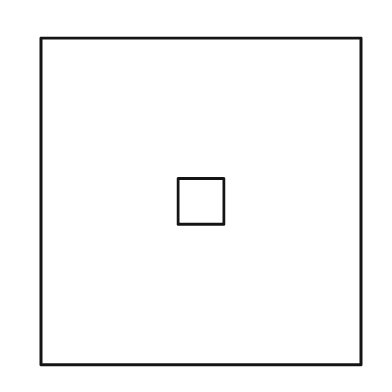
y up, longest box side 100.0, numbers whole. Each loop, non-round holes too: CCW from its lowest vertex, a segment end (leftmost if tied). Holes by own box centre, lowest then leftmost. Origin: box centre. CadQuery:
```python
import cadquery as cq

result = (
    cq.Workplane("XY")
    .moveTo(-49.0, -50.0)
    .lineTo(49.0, -50.0)
    .lineTo(49.0, 50.0)
    .lineTo(-49.0, 50.0)
    .close()
    .moveTo(-7.0, -7.0)
    .lineTo(7.0, -7.0)
    .lineTo(7.0, 7.0)
    .lineTo(-7.0, 7.0)
    .close()
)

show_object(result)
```